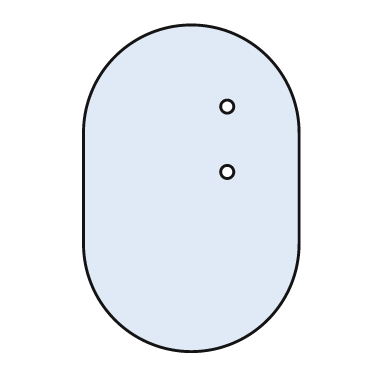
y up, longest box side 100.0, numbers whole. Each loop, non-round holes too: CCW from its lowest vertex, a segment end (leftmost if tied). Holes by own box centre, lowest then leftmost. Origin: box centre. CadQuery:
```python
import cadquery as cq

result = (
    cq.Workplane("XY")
    .moveTo(-33.0, -17.0)
    .threePointArc((0.0, -50.0), (33.0, -17.0))
    .lineTo(33.0, 17.0)
    .threePointArc((0.0, 50.0), (-33.0, 17.0))
    .close()
    .moveTo(11.0, 5.0)
    .circle(2.0)
    .moveTo(11.0, 25.0)
    .circle(2.0)
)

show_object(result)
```